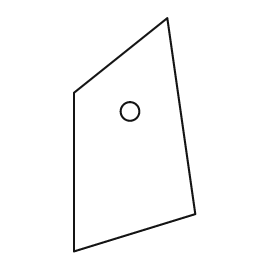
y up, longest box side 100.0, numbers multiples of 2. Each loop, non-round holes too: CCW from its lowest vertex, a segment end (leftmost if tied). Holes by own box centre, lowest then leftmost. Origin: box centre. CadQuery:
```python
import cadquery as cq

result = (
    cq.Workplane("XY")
    .moveTo(-26.0, -50.0)
    .lineTo(26.0, -34.0)
    .lineTo(14.0, 50.0)
    .lineTo(-26.0, 18.0)
    .close()
    .moveTo(-2.0, 10.0)
    .circle(4.0)
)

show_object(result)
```